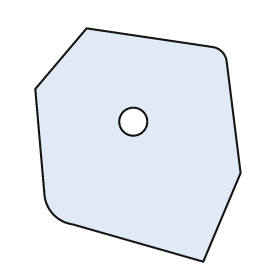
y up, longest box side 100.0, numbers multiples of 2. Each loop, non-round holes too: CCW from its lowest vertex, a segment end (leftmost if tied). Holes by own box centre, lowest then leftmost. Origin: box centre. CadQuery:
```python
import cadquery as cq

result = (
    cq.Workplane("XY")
    .moveTo(28.0, -50.0)
    .lineTo(44.0, -12.0)
    .lineTo(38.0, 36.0)
    .threePointArc((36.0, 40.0), (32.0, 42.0))
    .lineTo(-22.0, 50.0)
    .lineTo(-44.0, 24.0)
    .lineTo(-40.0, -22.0)
    .threePointArc((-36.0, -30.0), (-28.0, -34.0))
    .close()
    .moveTo(-2.0, 10.0)
    .circle(6.0)
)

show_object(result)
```